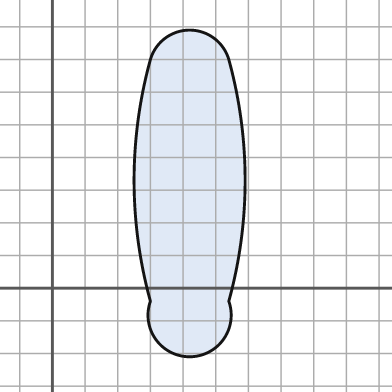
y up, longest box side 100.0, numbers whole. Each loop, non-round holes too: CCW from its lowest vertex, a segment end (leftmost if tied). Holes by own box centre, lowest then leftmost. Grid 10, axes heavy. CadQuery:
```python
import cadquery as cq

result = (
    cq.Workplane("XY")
    .moveTo(30.0, -4.0)
    .threePointArc((42.0, -21.0), (54.0, -4.0))
    .threePointArc((59.0, 33.0), (54.0, 70.0))
    .threePointArc((42.0, 79.0), (30.0, 70.0))
    .threePointArc((25.0, 33.0), (30.0, -4.0))
    .close()
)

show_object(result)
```